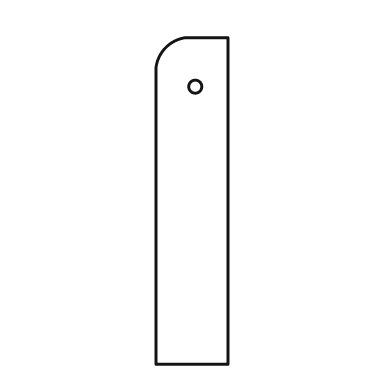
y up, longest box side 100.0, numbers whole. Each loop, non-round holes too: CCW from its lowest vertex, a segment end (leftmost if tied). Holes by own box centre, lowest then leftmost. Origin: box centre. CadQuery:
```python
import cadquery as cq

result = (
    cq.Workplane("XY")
    .moveTo(-11.0, -50.0)
    .lineTo(11.0, -50.0)
    .lineTo(11.0, 50.0)
    .lineTo(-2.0, 50.0)
    .threePointArc((-8.0, 47.0), (-11.0, 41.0))
    .close()
    .moveTo(1.0, 35.0)
    .circle(2.0)
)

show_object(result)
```